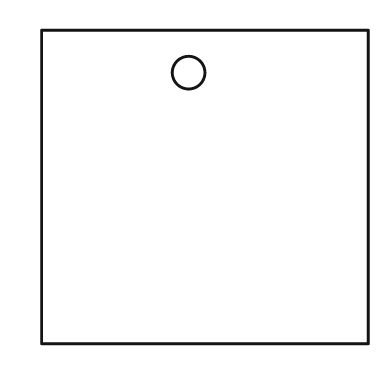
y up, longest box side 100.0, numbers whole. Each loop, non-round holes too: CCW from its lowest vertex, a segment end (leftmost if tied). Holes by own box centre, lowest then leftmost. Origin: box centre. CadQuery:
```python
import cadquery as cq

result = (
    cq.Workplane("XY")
    .moveTo(-50.0, -48.0)
    .lineTo(50.0, -48.0)
    .lineTo(50.0, 48.0)
    .lineTo(-50.0, 48.0)
    .close()
    .moveTo(-5.0, 35.0)
    .circle(5.0)
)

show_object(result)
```